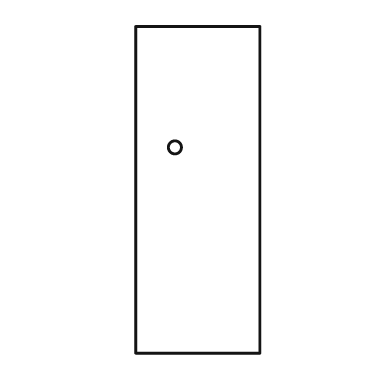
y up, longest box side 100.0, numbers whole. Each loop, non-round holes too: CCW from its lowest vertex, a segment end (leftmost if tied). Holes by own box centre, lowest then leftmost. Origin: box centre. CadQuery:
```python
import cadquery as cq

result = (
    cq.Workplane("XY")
    .moveTo(-19.0, -50.0)
    .lineTo(19.0, -50.0)
    .lineTo(19.0, 50.0)
    .lineTo(-19.0, 50.0)
    .close()
    .moveTo(-7.0, 13.0)
    .circle(2.0)
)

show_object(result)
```